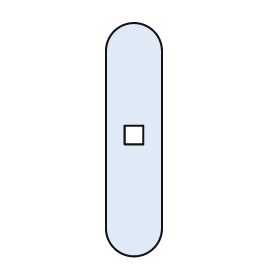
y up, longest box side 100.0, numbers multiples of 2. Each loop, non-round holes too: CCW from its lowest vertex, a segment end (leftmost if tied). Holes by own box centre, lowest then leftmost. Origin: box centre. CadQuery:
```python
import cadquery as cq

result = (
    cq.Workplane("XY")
    .moveTo(-12.0, -38.0)
    .threePointArc((0.0, -50.0), (12.0, -38.0))
    .lineTo(12.0, 38.0)
    .threePointArc((0.0, 50.0), (-12.0, 38.0))
    .close()
    .moveTo(-4.0, -2.0)
    .lineTo(4.0, -2.0)
    .lineTo(4.0, 6.0)
    .lineTo(-4.0, 6.0)
    .close()
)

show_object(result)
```